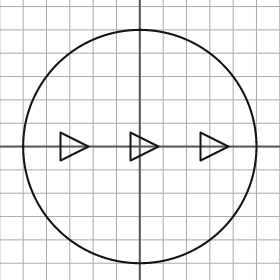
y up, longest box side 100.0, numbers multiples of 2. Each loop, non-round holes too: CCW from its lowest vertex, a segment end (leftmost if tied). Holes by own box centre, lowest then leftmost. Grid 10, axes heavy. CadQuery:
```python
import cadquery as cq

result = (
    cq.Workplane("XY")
    .moveTo(0.0, 0.0)
    .circle(50.0)
    .moveTo(-34.0, -6.0)
    .lineTo(-22.0, 0.0)
    .lineTo(-34.0, 6.0)
    .close()
    .moveTo(-4.0, -6.0)
    .lineTo(8.0, 0.0)
    .lineTo(-4.0, 6.0)
    .close()
    .moveTo(26.0, -6.0)
    .lineTo(38.0, 0.0)
    .lineTo(26.0, 6.0)
    .close()
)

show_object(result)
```